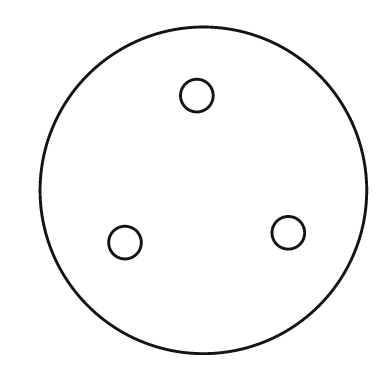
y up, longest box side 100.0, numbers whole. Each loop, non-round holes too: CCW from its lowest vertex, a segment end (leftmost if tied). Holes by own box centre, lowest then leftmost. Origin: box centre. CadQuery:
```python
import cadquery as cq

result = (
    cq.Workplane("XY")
    .moveTo(0.0, 0.0)
    .circle(50.0)
    .moveTo(-24.0, -16.0)
    .circle(5.0)
    .moveTo(26.0, -13.0)
    .circle(5.0)
    .moveTo(-2.0, 29.0)
    .circle(5.0)
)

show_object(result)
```